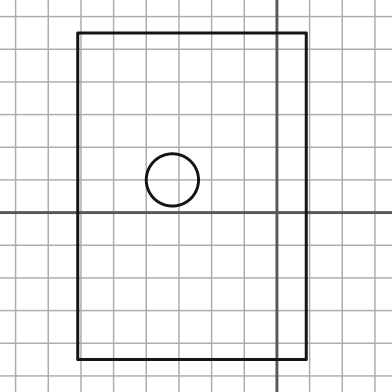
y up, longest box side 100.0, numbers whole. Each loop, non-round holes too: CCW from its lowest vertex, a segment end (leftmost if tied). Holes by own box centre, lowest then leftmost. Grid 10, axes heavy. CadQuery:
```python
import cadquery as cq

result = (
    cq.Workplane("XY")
    .moveTo(-61.0, -45.0)
    .lineTo(9.0, -45.0)
    .lineTo(9.0, 55.0)
    .lineTo(-61.0, 55.0)
    .close()
    .moveTo(-32.0, 10.0)
    .circle(8.0)
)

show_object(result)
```